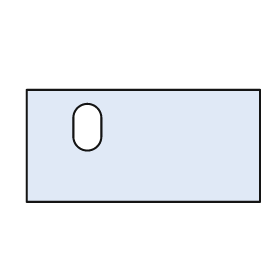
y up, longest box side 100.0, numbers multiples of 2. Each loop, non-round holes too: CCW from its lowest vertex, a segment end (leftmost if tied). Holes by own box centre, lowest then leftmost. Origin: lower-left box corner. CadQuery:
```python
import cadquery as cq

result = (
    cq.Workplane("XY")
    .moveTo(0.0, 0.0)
    .lineTo(100.0, 0.0)
    .lineTo(100.0, 48.0)
    .lineTo(0.0, 48.0)
    .close()
    .moveTo(20.0, 28.0)
    .threePointArc((26.0, 22.0), (32.0, 28.0))
    .lineTo(32.0, 36.0)
    .threePointArc((26.0, 42.0), (20.0, 36.0))
    .close()
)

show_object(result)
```